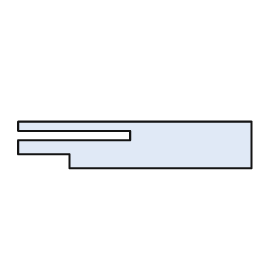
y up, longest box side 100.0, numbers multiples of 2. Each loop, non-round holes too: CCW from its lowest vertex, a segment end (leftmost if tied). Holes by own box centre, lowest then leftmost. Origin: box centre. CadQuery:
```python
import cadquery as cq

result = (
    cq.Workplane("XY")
    .moveTo(-28.0, -10.0)
    .lineTo(50.0, -10.0)
    .lineTo(50.0, 10.0)
    .lineTo(-50.0, 10.0)
    .lineTo(-50.0, 6.0)
    .lineTo(-2.0, 6.0)
    .lineTo(-2.0, 2.0)
    .lineTo(-50.0, 2.0)
    .lineTo(-50.0, -4.0)
    .lineTo(-28.0, -4.0)
    .close()
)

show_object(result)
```